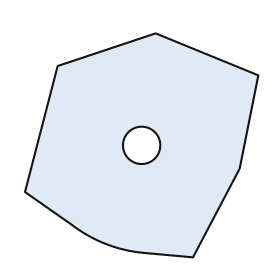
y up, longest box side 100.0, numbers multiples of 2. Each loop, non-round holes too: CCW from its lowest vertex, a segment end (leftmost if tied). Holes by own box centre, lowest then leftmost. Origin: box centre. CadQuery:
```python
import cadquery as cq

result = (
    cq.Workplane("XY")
    .moveTo(22.0, -48.0)
    .lineTo(42.0, -10.0)
    .lineTo(50.0, 30.0)
    .lineTo(6.0, 48.0)
    .lineTo(-36.0, 34.0)
    .lineTo(-50.0, -20.0)
    .lineTo(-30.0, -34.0)
    .threePointArc((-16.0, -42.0), (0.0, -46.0))
    .close()
    .moveTo(0.0, 0.0)
    .circle(8.0)
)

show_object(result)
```